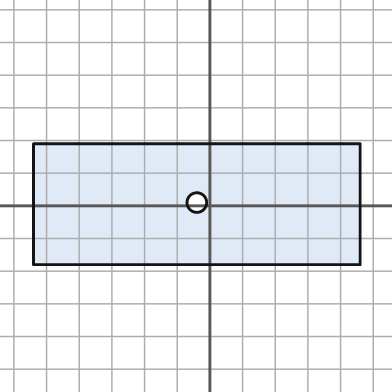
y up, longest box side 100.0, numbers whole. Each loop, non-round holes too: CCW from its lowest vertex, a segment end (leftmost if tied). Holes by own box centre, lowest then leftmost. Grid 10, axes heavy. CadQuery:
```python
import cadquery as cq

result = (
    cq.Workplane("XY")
    .moveTo(-54.0, -18.0)
    .lineTo(46.0, -18.0)
    .lineTo(46.0, 19.0)
    .lineTo(-54.0, 19.0)
    .close()
    .moveTo(-4.0, 1.0)
    .circle(3.0)
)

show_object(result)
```